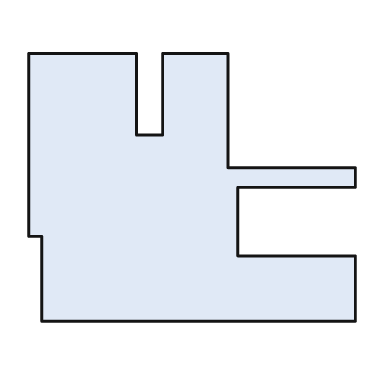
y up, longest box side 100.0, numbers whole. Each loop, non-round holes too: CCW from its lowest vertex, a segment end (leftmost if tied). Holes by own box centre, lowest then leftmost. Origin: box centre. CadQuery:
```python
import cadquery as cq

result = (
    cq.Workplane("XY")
    .moveTo(-46.0, -41.0)
    .lineTo(50.0, -41.0)
    .lineTo(50.0, -21.0)
    .lineTo(14.0, -21.0)
    .lineTo(14.0, 0.0)
    .lineTo(50.0, 0.0)
    .lineTo(50.0, 6.0)
    .lineTo(11.0, 6.0)
    .lineTo(11.0, 41.0)
    .lineTo(-9.0, 41.0)
    .lineTo(-9.0, 16.0)
    .lineTo(-17.0, 16.0)
    .lineTo(-17.0, 41.0)
    .lineTo(-50.0, 41.0)
    .lineTo(-50.0, -15.0)
    .lineTo(-46.0, -15.0)
    .close()
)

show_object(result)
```